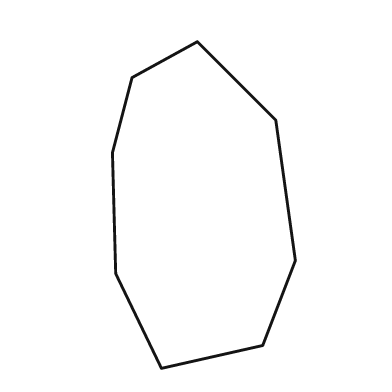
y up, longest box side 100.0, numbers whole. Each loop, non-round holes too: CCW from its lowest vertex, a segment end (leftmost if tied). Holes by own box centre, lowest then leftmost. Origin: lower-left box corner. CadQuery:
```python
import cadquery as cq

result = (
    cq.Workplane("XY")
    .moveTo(15.0, 0.0)
    .lineTo(46.0, 7.0)
    .lineTo(56.0, 33.0)
    .lineTo(50.0, 76.0)
    .lineTo(26.0, 100.0)
    .lineTo(6.0, 89.0)
    .lineTo(0.0, 66.0)
    .lineTo(1.0, 29.0)
    .close()
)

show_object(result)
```